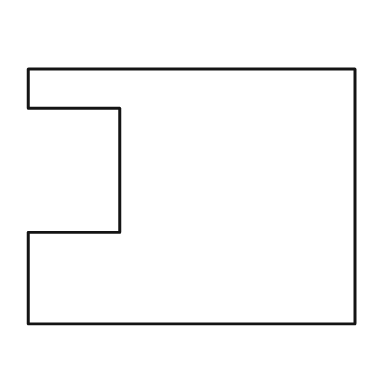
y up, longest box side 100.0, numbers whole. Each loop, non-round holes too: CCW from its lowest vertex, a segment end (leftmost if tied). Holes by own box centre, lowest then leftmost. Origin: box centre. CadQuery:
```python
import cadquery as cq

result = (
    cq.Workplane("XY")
    .moveTo(-50.0, -39.0)
    .lineTo(50.0, -39.0)
    .lineTo(50.0, 39.0)
    .lineTo(-50.0, 39.0)
    .lineTo(-50.0, 27.0)
    .lineTo(-22.0, 27.0)
    .lineTo(-22.0, -11.0)
    .lineTo(-50.0, -11.0)
    .close()
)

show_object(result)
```